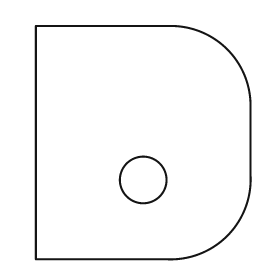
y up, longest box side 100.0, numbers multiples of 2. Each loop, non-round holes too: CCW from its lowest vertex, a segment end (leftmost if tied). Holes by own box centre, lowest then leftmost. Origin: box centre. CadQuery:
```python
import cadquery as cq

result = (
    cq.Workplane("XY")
    .moveTo(-46.0, -50.0)
    .lineTo(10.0, -50.0)
    .threePointArc((36.0, -40.0), (46.0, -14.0))
    .lineTo(46.0, 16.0)
    .threePointArc((36.0, 40.0), (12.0, 50.0))
    .lineTo(-46.0, 50.0)
    .close()
    .moveTo(0.0, -16.0)
    .circle(10.0)
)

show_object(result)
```